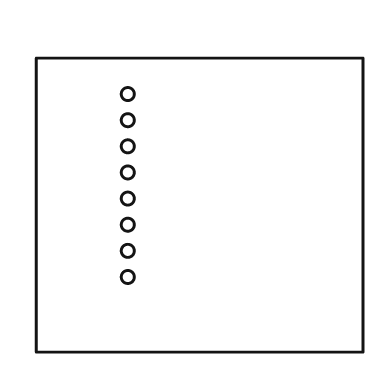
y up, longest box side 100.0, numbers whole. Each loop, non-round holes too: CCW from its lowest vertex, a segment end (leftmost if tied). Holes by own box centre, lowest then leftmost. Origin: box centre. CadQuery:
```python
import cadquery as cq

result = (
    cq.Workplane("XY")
    .moveTo(-50.0, -45.0)
    .lineTo(50.0, -45.0)
    .lineTo(50.0, 45.0)
    .lineTo(-50.0, 45.0)
    .close()
    .moveTo(-22.0, -22.0)
    .circle(2.0)
    .moveTo(-22.0, -14.0)
    .circle(2.0)
    .moveTo(-22.0, -6.0)
    .circle(2.0)
    .moveTo(-22.0, 2.0)
    .circle(2.0)
    .moveTo(-22.0, 10.0)
    .circle(2.0)
    .moveTo(-22.0, 18.0)
    .circle(2.0)
    .moveTo(-22.0, 26.0)
    .circle(2.0)
    .moveTo(-22.0, 34.0)
    .circle(2.0)
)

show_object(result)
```